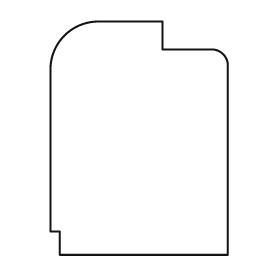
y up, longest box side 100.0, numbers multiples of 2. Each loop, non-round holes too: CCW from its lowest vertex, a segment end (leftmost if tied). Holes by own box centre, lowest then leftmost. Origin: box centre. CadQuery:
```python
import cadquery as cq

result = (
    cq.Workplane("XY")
    .moveTo(-34.0, -50.0)
    .lineTo(38.0, -50.0)
    .lineTo(38.0, 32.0)
    .threePointArc((36.0, 36.0), (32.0, 38.0))
    .lineTo(10.0, 38.0)
    .lineTo(10.0, 50.0)
    .lineTo(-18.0, 50.0)
    .threePointArc((-32.0, 44.0), (-38.0, 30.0))
    .lineTo(-38.0, -40.0)
    .lineTo(-34.0, -40.0)
    .close()
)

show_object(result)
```